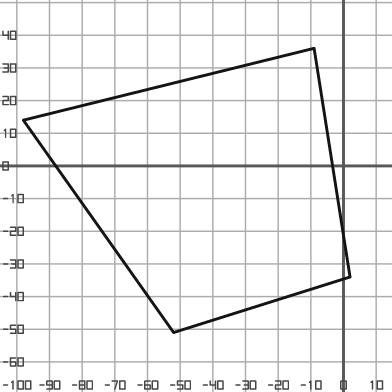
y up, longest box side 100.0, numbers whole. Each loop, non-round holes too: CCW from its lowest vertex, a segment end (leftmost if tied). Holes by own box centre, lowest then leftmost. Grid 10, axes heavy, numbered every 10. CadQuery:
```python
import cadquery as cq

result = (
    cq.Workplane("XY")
    .moveTo(-52.0, -51.0)
    .lineTo(2.0, -34.0)
    .lineTo(-9.0, 36.0)
    .lineTo(-98.0, 14.0)
    .close()
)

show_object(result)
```